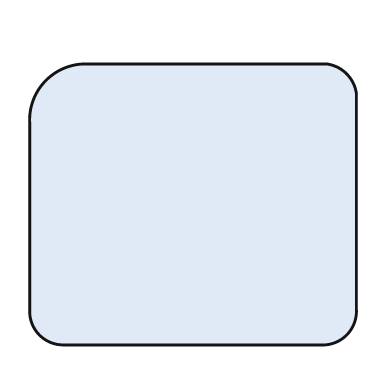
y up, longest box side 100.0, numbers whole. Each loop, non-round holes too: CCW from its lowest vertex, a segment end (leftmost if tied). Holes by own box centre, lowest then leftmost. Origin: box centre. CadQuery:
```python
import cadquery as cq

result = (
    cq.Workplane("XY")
    .moveTo(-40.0, -43.0)
    .lineTo(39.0, -43.0)
    .threePointArc((47.0, -40.0), (50.0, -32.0))
    .lineTo(50.0, 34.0)
    .threePointArc((47.0, 40.0), (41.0, 43.0))
    .lineTo(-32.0, 43.0)
    .threePointArc((-45.0, 38.0), (-50.0, 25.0))
    .lineTo(-50.0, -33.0)
    .threePointArc((-47.0, -40.0), (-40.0, -43.0))
    .close()
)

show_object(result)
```